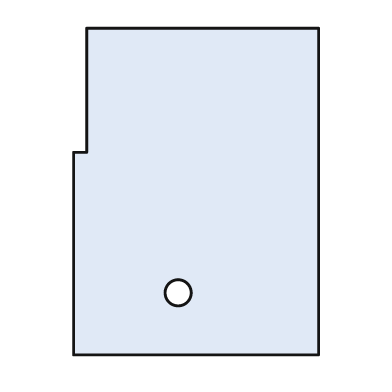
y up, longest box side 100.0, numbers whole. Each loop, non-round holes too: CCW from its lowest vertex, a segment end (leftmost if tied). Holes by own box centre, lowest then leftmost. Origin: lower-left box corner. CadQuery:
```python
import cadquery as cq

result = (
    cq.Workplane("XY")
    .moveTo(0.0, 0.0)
    .lineTo(75.0, 0.0)
    .lineTo(75.0, 100.0)
    .lineTo(4.0, 100.0)
    .lineTo(4.0, 62.0)
    .lineTo(0.0, 62.0)
    .close()
    .moveTo(32.0, 19.0)
    .circle(4.0)
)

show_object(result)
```